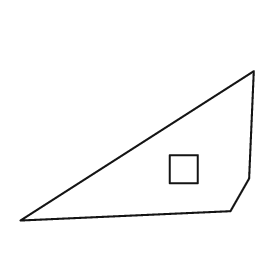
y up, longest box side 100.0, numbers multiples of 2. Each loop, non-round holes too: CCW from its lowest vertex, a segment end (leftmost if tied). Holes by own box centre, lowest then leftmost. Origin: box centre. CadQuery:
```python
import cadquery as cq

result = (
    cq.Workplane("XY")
    .moveTo(-50.0, -32.0)
    .lineTo(40.0, -28.0)
    .lineTo(48.0, -14.0)
    .lineTo(50.0, 32.0)
    .close()
    .moveTo(14.0, -16.0)
    .lineTo(26.0, -16.0)
    .lineTo(26.0, -4.0)
    .lineTo(14.0, -4.0)
    .close()
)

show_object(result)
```